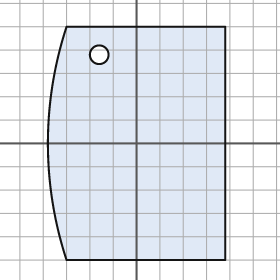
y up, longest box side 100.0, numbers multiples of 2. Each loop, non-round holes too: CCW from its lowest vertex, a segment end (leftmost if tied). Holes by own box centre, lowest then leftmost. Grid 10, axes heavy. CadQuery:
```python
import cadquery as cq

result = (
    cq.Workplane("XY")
    .moveTo(-30.0, -50.0)
    .lineTo(38.0, -50.0)
    .lineTo(38.0, 50.0)
    .lineTo(-30.0, 50.0)
    .threePointArc((-38.0, 0.0), (-30.0, -50.0))
    .close()
    .moveTo(-16.0, 38.0)
    .circle(4.0)
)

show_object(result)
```